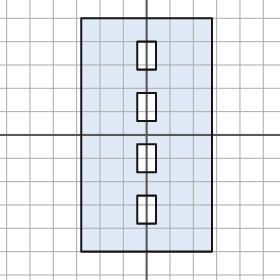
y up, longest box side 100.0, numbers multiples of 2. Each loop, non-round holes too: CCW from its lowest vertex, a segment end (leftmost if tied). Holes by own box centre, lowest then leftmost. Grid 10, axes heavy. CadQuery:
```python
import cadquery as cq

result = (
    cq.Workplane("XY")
    .moveTo(-28.0, -50.0)
    .lineTo(28.0, -50.0)
    .lineTo(28.0, 50.0)
    .lineTo(-28.0, 50.0)
    .close()
    .moveTo(-4.0, -38.0)
    .lineTo(4.0, -38.0)
    .lineTo(4.0, -26.0)
    .lineTo(-4.0, -26.0)
    .close()
    .moveTo(-4.0, -16.0)
    .lineTo(4.0, -16.0)
    .lineTo(4.0, -4.0)
    .lineTo(-4.0, -4.0)
    .close()
    .moveTo(-4.0, 6.0)
    .lineTo(4.0, 6.0)
    .lineTo(4.0, 18.0)
    .lineTo(-4.0, 18.0)
    .close()
    .moveTo(-4.0, 28.0)
    .lineTo(4.0, 28.0)
    .lineTo(4.0, 40.0)
    .lineTo(-4.0, 40.0)
    .close()
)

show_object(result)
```